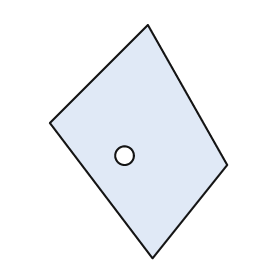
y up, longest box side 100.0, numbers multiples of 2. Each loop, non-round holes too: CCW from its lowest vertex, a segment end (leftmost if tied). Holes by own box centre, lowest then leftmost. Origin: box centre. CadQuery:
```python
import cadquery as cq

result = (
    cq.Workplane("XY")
    .moveTo(6.0, -50.0)
    .lineTo(38.0, -10.0)
    .lineTo(4.0, 50.0)
    .lineTo(-38.0, 8.0)
    .close()
    .moveTo(-6.0, -6.0)
    .circle(4.0)
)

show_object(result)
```